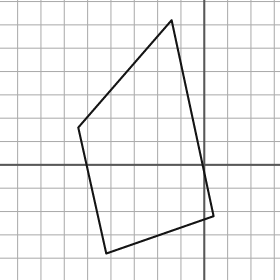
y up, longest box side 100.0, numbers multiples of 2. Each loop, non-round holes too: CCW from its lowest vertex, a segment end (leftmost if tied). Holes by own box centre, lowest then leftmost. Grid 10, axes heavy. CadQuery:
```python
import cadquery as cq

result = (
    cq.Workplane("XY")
    .moveTo(-42.0, -38.0)
    .lineTo(4.0, -22.0)
    .lineTo(-14.0, 62.0)
    .lineTo(-54.0, 16.0)
    .close()
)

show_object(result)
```